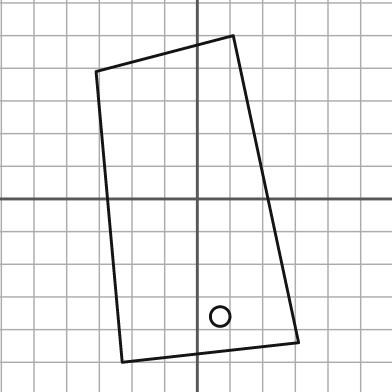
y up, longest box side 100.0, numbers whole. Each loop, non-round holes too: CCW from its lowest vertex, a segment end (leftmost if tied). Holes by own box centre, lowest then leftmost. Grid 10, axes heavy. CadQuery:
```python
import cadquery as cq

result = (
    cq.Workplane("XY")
    .moveTo(-23.0, -50.0)
    .lineTo(31.0, -44.0)
    .lineTo(11.0, 50.0)
    .lineTo(-31.0, 39.0)
    .close()
    .moveTo(7.0, -36.0)
    .circle(3.0)
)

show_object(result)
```